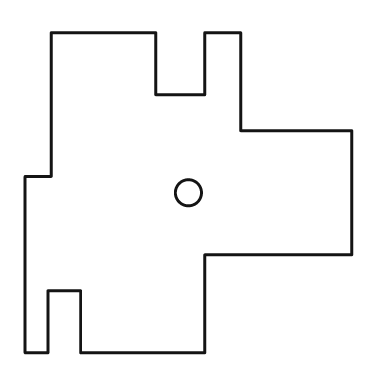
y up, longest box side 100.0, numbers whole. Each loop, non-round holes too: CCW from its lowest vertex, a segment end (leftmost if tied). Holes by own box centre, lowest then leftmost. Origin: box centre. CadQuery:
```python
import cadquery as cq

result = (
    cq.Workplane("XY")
    .moveTo(-50.0, -49.0)
    .lineTo(-43.0, -49.0)
    .lineTo(-43.0, -30.0)
    .lineTo(-33.0, -30.0)
    .lineTo(-33.0, -49.0)
    .lineTo(5.0, -49.0)
    .lineTo(5.0, -19.0)
    .lineTo(50.0, -19.0)
    .lineTo(50.0, 19.0)
    .lineTo(16.0, 19.0)
    .lineTo(16.0, 49.0)
    .lineTo(5.0, 49.0)
    .lineTo(5.0, 30.0)
    .lineTo(-10.0, 30.0)
    .lineTo(-10.0, 49.0)
    .lineTo(-42.0, 49.0)
    .lineTo(-42.0, 5.0)
    .lineTo(-50.0, 5.0)
    .close()
    .moveTo(0.0, 0.0)
    .circle(4.0)
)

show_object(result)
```